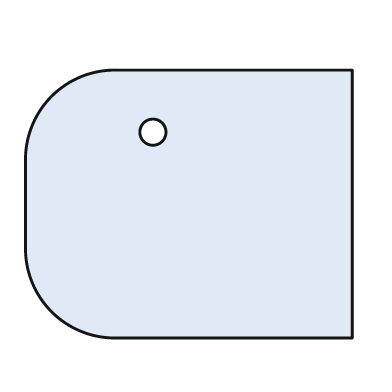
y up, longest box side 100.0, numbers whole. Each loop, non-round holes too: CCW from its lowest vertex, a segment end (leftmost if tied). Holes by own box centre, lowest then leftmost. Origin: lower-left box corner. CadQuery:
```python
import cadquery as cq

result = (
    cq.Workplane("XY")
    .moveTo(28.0, 0.0)
    .lineTo(100.0, 0.0)
    .lineTo(100.0, 82.0)
    .lineTo(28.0, 82.0)
    .threePointArc((8.0, 74.0), (0.0, 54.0))
    .lineTo(0.0, 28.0)
    .threePointArc((8.0, 8.0), (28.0, 0.0))
    .close()
    .moveTo(39.0, 63.0)
    .circle(4.0)
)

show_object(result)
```